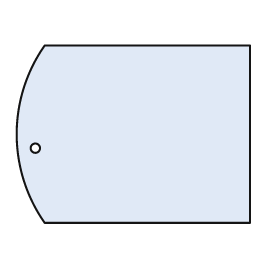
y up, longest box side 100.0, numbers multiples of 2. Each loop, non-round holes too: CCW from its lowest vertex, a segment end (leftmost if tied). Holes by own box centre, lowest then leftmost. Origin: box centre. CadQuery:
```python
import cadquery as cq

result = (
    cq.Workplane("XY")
    .moveTo(-38.0, -38.0)
    .lineTo(50.0, -38.0)
    .lineTo(50.0, 38.0)
    .lineTo(-38.0, 38.0)
    .threePointArc((-50.0, 0.0), (-38.0, -38.0))
    .close()
    .moveTo(-42.0, -6.0)
    .circle(2.0)
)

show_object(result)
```